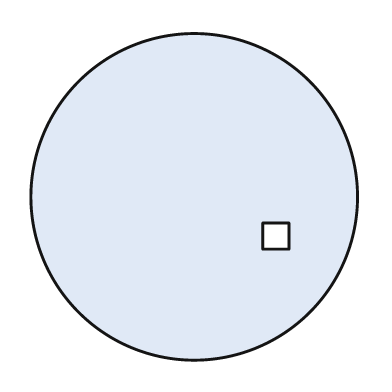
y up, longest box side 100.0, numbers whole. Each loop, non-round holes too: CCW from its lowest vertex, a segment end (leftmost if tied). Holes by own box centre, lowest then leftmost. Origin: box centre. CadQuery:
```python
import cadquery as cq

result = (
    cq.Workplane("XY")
    .moveTo(0.0, 0.0)
    .circle(50.0)
    .moveTo(21.0, -16.0)
    .lineTo(29.0, -16.0)
    .lineTo(29.0, -8.0)
    .lineTo(21.0, -8.0)
    .close()
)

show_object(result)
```